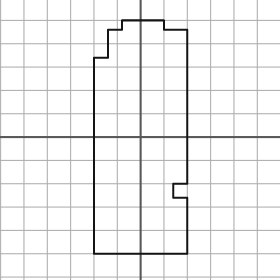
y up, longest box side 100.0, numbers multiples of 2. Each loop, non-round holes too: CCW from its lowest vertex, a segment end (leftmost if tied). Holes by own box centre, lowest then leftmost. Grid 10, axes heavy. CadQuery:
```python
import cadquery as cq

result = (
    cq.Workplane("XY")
    .moveTo(-20.0, -50.0)
    .lineTo(20.0, -50.0)
    .lineTo(20.0, -26.0)
    .lineTo(14.0, -26.0)
    .lineTo(14.0, -20.0)
    .lineTo(20.0, -20.0)
    .lineTo(20.0, 46.0)
    .lineTo(10.0, 46.0)
    .lineTo(10.0, 50.0)
    .lineTo(-8.0, 50.0)
    .lineTo(-8.0, 46.0)
    .lineTo(-14.0, 46.0)
    .lineTo(-14.0, 34.0)
    .lineTo(-20.0, 34.0)
    .close()
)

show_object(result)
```